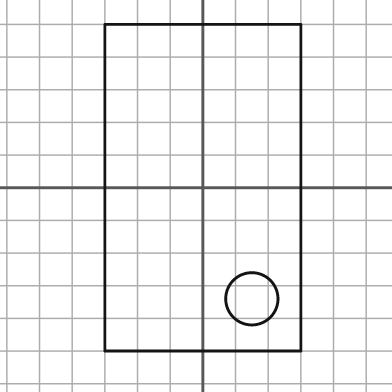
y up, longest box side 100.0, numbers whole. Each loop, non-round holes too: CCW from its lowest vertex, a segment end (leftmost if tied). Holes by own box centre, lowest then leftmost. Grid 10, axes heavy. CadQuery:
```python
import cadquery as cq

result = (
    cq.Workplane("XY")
    .moveTo(-30.0, -50.0)
    .lineTo(30.0, -50.0)
    .lineTo(30.0, 50.0)
    .lineTo(-30.0, 50.0)
    .close()
    .moveTo(15.0, -34.0)
    .circle(8.0)
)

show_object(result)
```